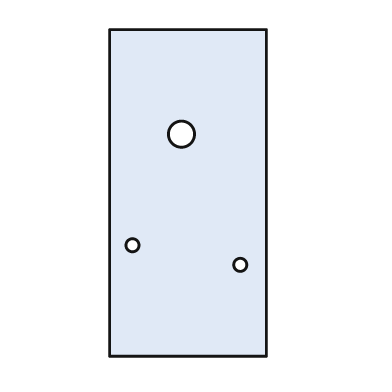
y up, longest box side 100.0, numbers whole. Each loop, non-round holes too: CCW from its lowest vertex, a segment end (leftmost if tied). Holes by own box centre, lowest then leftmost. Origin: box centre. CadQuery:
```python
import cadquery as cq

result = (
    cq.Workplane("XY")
    .moveTo(-24.0, -50.0)
    .lineTo(24.0, -50.0)
    .lineTo(24.0, 50.0)
    .lineTo(-24.0, 50.0)
    .close()
    .moveTo(16.0, -22.0)
    .circle(2.0)
    .moveTo(-17.0, -16.0)
    .circle(2.0)
    .moveTo(-2.0, 18.0)
    .circle(4.0)
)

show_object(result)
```